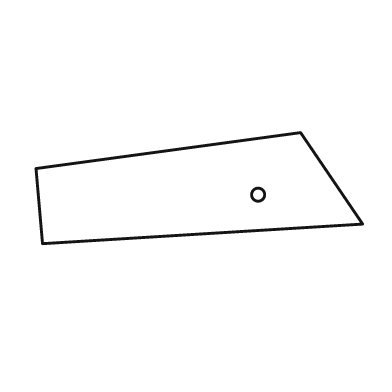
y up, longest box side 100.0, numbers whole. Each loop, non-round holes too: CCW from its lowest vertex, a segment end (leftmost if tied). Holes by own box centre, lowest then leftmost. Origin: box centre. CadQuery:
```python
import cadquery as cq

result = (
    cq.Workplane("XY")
    .moveTo(-48.0, -17.0)
    .lineTo(50.0, -11.0)
    .lineTo(31.0, 17.0)
    .lineTo(-50.0, 6.0)
    .close()
    .moveTo(18.0, -2.0)
    .circle(2.0)
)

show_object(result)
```